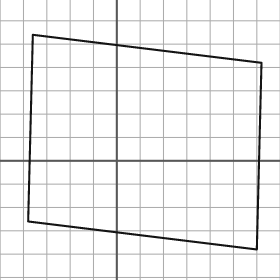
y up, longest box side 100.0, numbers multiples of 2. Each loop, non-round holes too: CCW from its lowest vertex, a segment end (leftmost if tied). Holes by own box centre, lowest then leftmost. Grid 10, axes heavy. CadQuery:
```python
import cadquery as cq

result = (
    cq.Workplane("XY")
    .moveTo(60.0, -38.0)
    .lineTo(62.0, 42.0)
    .lineTo(-36.0, 54.0)
    .lineTo(-38.0, -26.0)
    .close()
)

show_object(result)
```